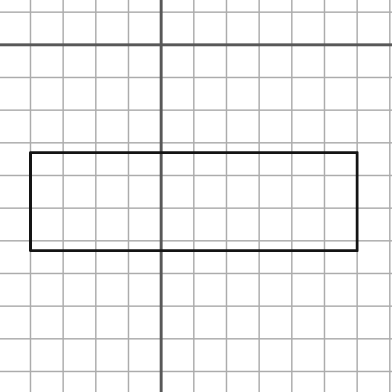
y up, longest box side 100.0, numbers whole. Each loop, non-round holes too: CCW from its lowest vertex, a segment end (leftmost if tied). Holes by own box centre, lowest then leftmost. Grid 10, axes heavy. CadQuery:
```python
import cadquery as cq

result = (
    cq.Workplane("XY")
    .moveTo(-40.0, -63.0)
    .lineTo(60.0, -63.0)
    .lineTo(60.0, -33.0)
    .lineTo(-40.0, -33.0)
    .close()
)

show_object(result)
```